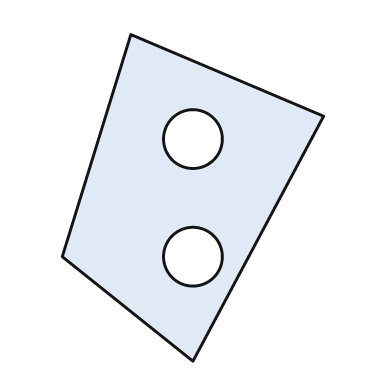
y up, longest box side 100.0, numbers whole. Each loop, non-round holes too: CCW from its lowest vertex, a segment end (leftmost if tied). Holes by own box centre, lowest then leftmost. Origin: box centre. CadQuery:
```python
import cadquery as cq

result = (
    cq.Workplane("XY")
    .moveTo(0.0, -50.0)
    .lineTo(40.0, 25.0)
    .lineTo(-19.0, 50.0)
    .lineTo(-40.0, -18.0)
    .close()
    .moveTo(0.0, -18.0)
    .circle(9.0)
    .moveTo(0.0, 18.0)
    .circle(9.0)
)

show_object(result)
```